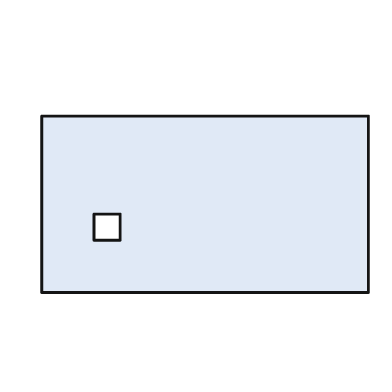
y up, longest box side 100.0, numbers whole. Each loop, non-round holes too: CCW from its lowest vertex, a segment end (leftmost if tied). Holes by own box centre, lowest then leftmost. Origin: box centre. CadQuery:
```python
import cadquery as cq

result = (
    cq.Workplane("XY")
    .moveTo(-50.0, -27.0)
    .lineTo(50.0, -27.0)
    .lineTo(50.0, 27.0)
    .lineTo(-50.0, 27.0)
    .close()
    .moveTo(-34.0, -11.0)
    .lineTo(-26.0, -11.0)
    .lineTo(-26.0, -3.0)
    .lineTo(-34.0, -3.0)
    .close()
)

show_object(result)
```